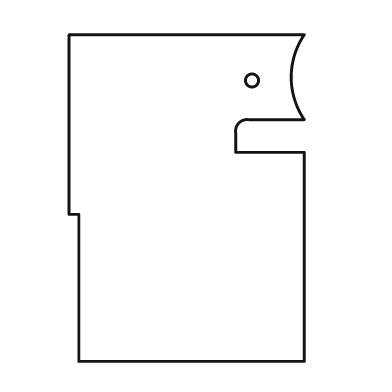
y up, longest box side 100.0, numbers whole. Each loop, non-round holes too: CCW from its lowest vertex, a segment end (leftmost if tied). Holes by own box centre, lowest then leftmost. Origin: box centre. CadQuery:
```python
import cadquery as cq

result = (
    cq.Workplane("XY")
    .moveTo(-33.0, -50.0)
    .lineTo(36.0, -50.0)
    .lineTo(36.0, 14.0)
    .lineTo(15.0, 14.0)
    .lineTo(15.0, 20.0)
    .threePointArc((16.0, 23.0), (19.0, 24.0))
    .lineTo(36.0, 24.0)
    .threePointArc((32.0, 37.0), (36.0, 50.0))
    .lineTo(-36.0, 50.0)
    .lineTo(-36.0, -5.0)
    .lineTo(-33.0, -5.0)
    .close()
    .moveTo(20.0, 36.0)
    .circle(2.0)
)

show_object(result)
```